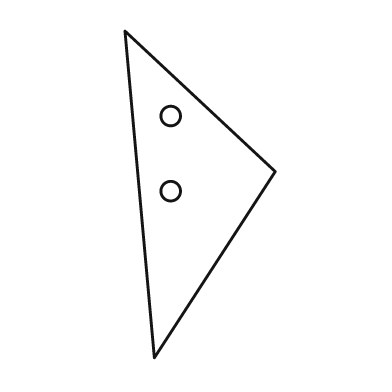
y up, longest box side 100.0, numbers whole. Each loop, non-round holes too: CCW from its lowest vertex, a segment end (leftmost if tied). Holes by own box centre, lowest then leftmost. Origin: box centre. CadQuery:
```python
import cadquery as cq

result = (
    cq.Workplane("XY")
    .moveTo(-14.0, -50.0)
    .lineTo(23.0, 7.0)
    .lineTo(-23.0, 50.0)
    .close()
    .moveTo(-9.0, 1.0)
    .circle(3.0)
    .moveTo(-9.0, 24.0)
    .circle(3.0)
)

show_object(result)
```